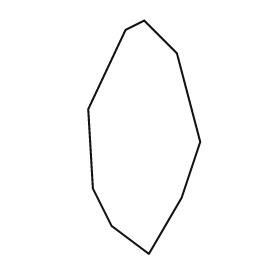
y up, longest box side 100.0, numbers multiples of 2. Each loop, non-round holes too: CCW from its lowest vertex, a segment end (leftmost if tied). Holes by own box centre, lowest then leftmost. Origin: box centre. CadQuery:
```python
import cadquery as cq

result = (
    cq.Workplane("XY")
    .moveTo(2.0, -50.0)
    .lineTo(16.0, -26.0)
    .lineTo(24.0, -2.0)
    .lineTo(14.0, 36.0)
    .lineTo(0.0, 50.0)
    .lineTo(-8.0, 46.0)
    .lineTo(-24.0, 12.0)
    .lineTo(-22.0, -22.0)
    .lineTo(-14.0, -38.0)
    .close()
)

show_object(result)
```